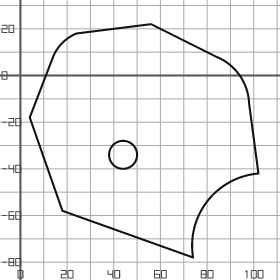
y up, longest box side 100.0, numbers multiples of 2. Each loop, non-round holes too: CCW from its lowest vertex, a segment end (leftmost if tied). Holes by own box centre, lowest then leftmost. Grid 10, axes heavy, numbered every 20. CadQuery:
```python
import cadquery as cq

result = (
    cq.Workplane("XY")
    .moveTo(74.0, -78.0)
    .threePointArc((80.0, -54.0), (102.0, -42.0))
    .lineTo(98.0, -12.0)
    .threePointArc((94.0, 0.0), (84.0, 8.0))
    .lineTo(56.0, 22.0)
    .lineTo(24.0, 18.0)
    .threePointArc((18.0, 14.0), (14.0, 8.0))
    .lineTo(4.0, -18.0)
    .lineTo(18.0, -58.0)
    .close()
    .moveTo(44.0, -34.0)
    .circle(6.0)
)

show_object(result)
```